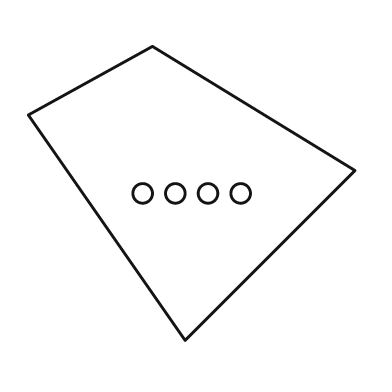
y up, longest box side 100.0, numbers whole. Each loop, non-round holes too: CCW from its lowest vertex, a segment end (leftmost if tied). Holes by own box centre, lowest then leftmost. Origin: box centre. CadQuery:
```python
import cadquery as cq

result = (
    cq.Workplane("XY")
    .moveTo(-2.0, -45.0)
    .lineTo(50.0, 7.0)
    .lineTo(-12.0, 45.0)
    .lineTo(-50.0, 24.0)
    .close()
    .moveTo(-15.0, 0.0)
    .circle(3.0)
    .moveTo(-5.0, 0.0)
    .circle(3.0)
    .moveTo(5.0, 0.0)
    .circle(3.0)
    .moveTo(15.0, 0.0)
    .circle(3.0)
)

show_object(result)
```